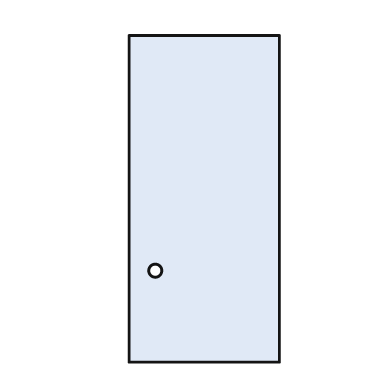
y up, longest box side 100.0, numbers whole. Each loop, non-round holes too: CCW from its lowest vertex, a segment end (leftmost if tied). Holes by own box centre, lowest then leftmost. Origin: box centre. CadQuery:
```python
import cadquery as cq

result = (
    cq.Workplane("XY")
    .moveTo(-23.0, -50.0)
    .lineTo(23.0, -50.0)
    .lineTo(23.0, 50.0)
    .lineTo(-23.0, 50.0)
    .close()
    .moveTo(-15.0, -22.0)
    .circle(2.0)
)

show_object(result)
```